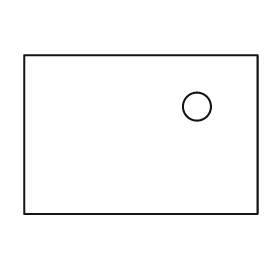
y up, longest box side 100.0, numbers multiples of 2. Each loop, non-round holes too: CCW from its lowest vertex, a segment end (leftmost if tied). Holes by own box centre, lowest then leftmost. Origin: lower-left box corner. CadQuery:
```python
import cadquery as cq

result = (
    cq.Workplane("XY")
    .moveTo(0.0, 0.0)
    .lineTo(100.0, 0.0)
    .lineTo(100.0, 68.0)
    .lineTo(0.0, 68.0)
    .close()
    .moveTo(74.0, 46.0)
    .circle(6.0)
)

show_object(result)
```